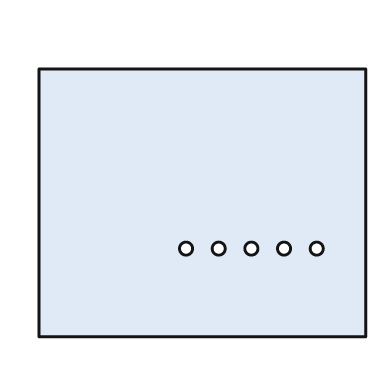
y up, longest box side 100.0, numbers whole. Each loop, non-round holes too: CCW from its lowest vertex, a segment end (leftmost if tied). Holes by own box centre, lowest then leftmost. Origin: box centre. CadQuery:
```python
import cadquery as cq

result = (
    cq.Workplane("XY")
    .moveTo(-50.0, -41.0)
    .lineTo(50.0, -41.0)
    .lineTo(50.0, 41.0)
    .lineTo(-50.0, 41.0)
    .close()
    .moveTo(-5.0, -14.0)
    .circle(2.0)
    .moveTo(5.0, -14.0)
    .circle(2.0)
    .moveTo(15.0, -14.0)
    .circle(2.0)
    .moveTo(25.0, -14.0)
    .circle(2.0)
    .moveTo(35.0, -14.0)
    .circle(2.0)
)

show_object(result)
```